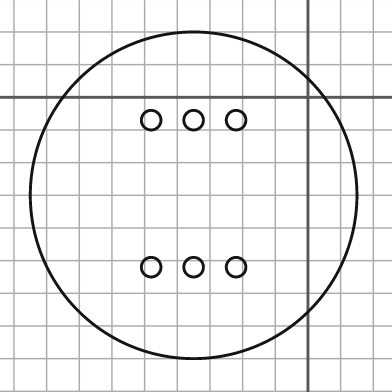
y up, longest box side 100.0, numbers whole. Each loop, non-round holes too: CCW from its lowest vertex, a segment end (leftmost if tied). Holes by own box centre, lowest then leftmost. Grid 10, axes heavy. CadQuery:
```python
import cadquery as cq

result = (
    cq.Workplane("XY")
    .moveTo(-35.0, -30.0)
    .circle(50.0)
    .moveTo(-48.0, -52.0)
    .circle(3.0)
    .moveTo(-35.0, -52.0)
    .circle(3.0)
    .moveTo(-22.0, -52.0)
    .circle(3.0)
    .moveTo(-48.0, -7.0)
    .circle(3.0)
    .moveTo(-35.0, -7.0)
    .circle(3.0)
    .moveTo(-22.0, -7.0)
    .circle(3.0)
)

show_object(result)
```